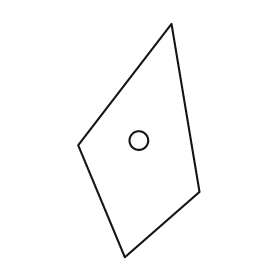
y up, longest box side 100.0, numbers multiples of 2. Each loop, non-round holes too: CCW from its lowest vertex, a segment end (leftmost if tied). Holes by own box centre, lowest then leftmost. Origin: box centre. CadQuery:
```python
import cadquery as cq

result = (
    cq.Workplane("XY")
    .moveTo(-6.0, -50.0)
    .lineTo(26.0, -22.0)
    .lineTo(14.0, 50.0)
    .lineTo(-26.0, -2.0)
    .close()
    .moveTo(0.0, 0.0)
    .circle(4.0)
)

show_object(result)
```